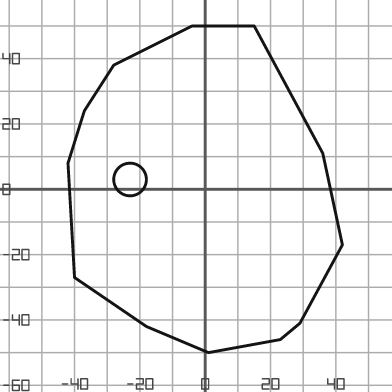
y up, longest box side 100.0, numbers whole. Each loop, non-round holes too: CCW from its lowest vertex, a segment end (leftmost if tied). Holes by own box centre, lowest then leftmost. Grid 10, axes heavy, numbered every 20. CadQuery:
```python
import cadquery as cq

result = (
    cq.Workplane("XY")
    .moveTo(1.0, -50.0)
    .lineTo(23.0, -46.0)
    .lineTo(29.0, -41.0)
    .lineTo(42.0, -17.0)
    .lineTo(36.0, 11.0)
    .lineTo(15.0, 50.0)
    .lineTo(-4.0, 50.0)
    .lineTo(-28.0, 38.0)
    .lineTo(-37.0, 24.0)
    .lineTo(-42.0, 8.0)
    .lineTo(-40.0, -27.0)
    .lineTo(-18.0, -42.0)
    .close()
    .moveTo(-23.0, 3.0)
    .circle(5.0)
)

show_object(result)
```